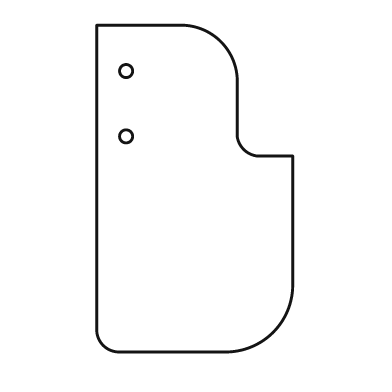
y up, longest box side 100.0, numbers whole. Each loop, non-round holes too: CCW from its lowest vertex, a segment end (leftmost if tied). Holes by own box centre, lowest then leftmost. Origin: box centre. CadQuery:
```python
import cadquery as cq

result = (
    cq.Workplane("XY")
    .moveTo(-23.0, -50.0)
    .lineTo(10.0, -50.0)
    .threePointArc((24.0, -44.0), (30.0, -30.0))
    .lineTo(30.0, 10.0)
    .lineTo(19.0, 10.0)
    .threePointArc((15.0, 12.0), (13.0, 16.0))
    .lineTo(13.0, 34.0)
    .threePointArc((8.0, 45.0), (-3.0, 50.0))
    .lineTo(-30.0, 50.0)
    .lineTo(-30.0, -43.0)
    .threePointArc((-28.0, -48.0), (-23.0, -50.0))
    .close()
    .moveTo(-21.0, 16.0)
    .circle(2.0)
    .moveTo(-21.0, 36.0)
    .circle(2.0)
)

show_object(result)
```